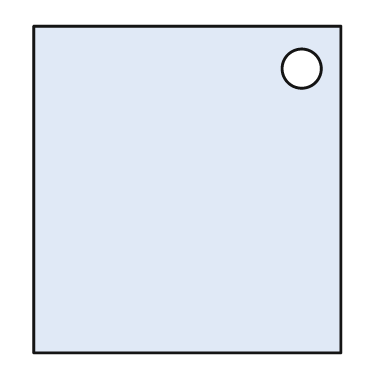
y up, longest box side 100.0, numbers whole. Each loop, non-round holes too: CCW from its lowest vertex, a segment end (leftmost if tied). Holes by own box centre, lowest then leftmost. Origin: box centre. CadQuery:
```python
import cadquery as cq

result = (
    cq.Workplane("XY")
    .moveTo(-47.0, -50.0)
    .lineTo(47.0, -50.0)
    .lineTo(47.0, 50.0)
    .lineTo(-47.0, 50.0)
    .close()
    .moveTo(35.0, 37.0)
    .circle(6.0)
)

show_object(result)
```